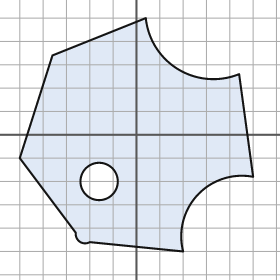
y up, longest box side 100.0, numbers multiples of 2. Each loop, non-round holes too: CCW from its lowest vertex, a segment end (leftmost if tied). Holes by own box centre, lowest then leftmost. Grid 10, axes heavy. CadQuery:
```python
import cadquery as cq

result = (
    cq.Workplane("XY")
    .moveTo(20.0, -50.0)
    .threePointArc((26.0, -26.0), (50.0, -18.0))
    .lineTo(44.0, 26.0)
    .threePointArc((18.0, 28.0), (4.0, 50.0))
    .lineTo(-36.0, 34.0)
    .lineTo(-50.0, -10.0)
    .lineTo(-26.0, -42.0)
    .threePointArc((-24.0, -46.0), (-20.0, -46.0))
    .close()
    .moveTo(-16.0, -20.0)
    .circle(8.0)
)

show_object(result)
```